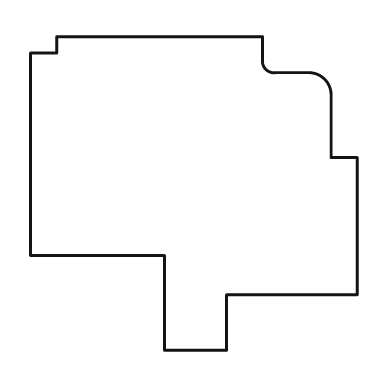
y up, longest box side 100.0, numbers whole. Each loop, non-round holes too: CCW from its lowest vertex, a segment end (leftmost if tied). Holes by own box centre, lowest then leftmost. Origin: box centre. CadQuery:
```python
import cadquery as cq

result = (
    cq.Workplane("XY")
    .moveTo(-9.0, -48.0)
    .lineTo(10.0, -48.0)
    .lineTo(10.0, -31.0)
    .lineTo(50.0, -31.0)
    .lineTo(50.0, 11.0)
    .lineTo(42.0, 11.0)
    .lineTo(42.0, 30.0)
    .threePointArc((40.0, 35.0), (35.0, 37.0))
    .lineTo(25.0, 37.0)
    .threePointArc((22.0, 38.0), (21.0, 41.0))
    .lineTo(21.0, 48.0)
    .lineTo(-42.0, 48.0)
    .lineTo(-42.0, 43.0)
    .lineTo(-50.0, 43.0)
    .lineTo(-50.0, -19.0)
    .lineTo(-9.0, -19.0)
    .close()
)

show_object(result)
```